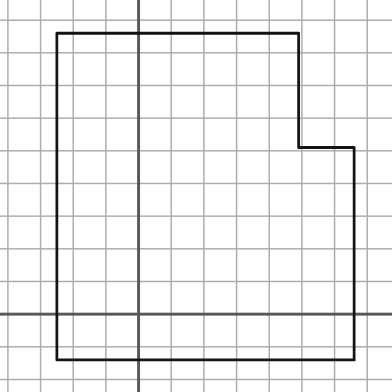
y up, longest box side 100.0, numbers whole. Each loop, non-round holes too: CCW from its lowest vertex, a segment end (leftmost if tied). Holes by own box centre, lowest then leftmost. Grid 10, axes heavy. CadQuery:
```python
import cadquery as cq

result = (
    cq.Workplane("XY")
    .moveTo(-25.0, -14.0)
    .lineTo(66.0, -14.0)
    .lineTo(66.0, 51.0)
    .lineTo(49.0, 51.0)
    .lineTo(49.0, 86.0)
    .lineTo(-25.0, 86.0)
    .close()
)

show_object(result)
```